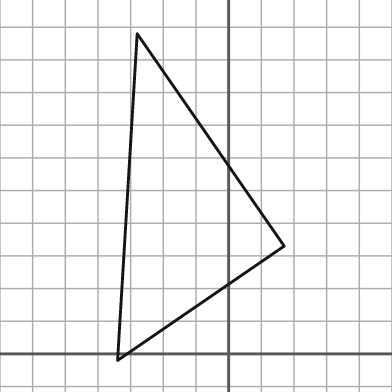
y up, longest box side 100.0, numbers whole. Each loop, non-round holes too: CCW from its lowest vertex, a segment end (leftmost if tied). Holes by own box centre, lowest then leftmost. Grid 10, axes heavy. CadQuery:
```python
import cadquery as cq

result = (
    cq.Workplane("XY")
    .moveTo(-34.0, -2.0)
    .lineTo(17.0, 33.0)
    .lineTo(-28.0, 98.0)
    .close()
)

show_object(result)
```